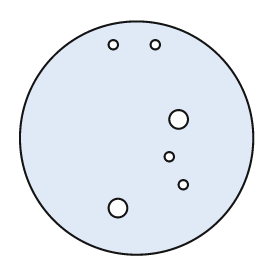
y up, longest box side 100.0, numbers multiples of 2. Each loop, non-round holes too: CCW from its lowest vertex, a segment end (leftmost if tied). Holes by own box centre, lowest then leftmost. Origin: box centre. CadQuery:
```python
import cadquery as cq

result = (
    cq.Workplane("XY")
    .moveTo(0.0, 0.0)
    .circle(50.0)
    .moveTo(-8.0, -30.0)
    .circle(4.0)
    .moveTo(20.0, -20.0)
    .circle(2.0)
    .moveTo(14.0, -8.0)
    .circle(2.0)
    .moveTo(18.0, 8.0)
    .circle(4.0)
    .moveTo(-10.0, 40.0)
    .circle(2.0)
    .moveTo(8.0, 40.0)
    .circle(2.0)
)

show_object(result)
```